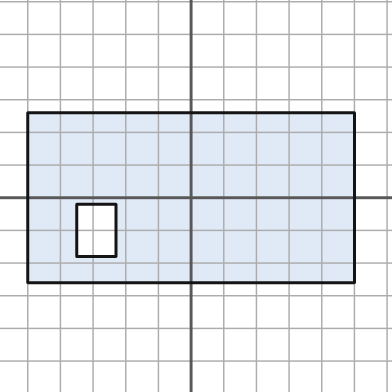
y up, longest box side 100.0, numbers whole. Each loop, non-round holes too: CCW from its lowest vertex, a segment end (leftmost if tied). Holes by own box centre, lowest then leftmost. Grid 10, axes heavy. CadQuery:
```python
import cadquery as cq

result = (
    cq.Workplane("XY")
    .moveTo(-50.0, -26.0)
    .lineTo(50.0, -26.0)
    .lineTo(50.0, 26.0)
    .lineTo(-50.0, 26.0)
    .close()
    .moveTo(-35.0, -18.0)
    .lineTo(-23.0, -18.0)
    .lineTo(-23.0, -2.0)
    .lineTo(-35.0, -2.0)
    .close()
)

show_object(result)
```